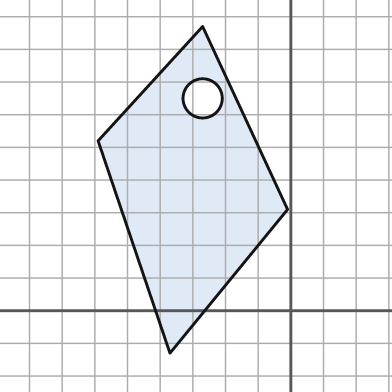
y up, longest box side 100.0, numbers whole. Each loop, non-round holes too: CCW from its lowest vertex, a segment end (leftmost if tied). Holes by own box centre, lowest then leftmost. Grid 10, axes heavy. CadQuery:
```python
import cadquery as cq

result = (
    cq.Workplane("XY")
    .moveTo(-37.0, -13.0)
    .lineTo(-1.0, 31.0)
    .lineTo(-27.0, 87.0)
    .lineTo(-59.0, 52.0)
    .close()
    .moveTo(-27.0, 65.0)
    .circle(6.0)
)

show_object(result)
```